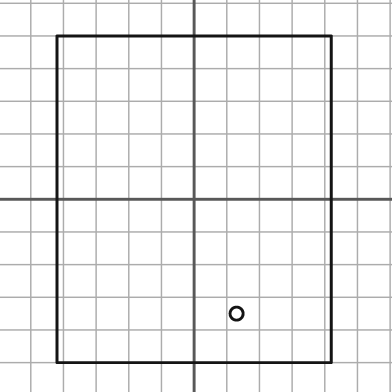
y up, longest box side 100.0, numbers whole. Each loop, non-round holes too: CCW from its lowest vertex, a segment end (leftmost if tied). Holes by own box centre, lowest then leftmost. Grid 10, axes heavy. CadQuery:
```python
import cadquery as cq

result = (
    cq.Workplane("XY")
    .moveTo(-42.0, -50.0)
    .lineTo(42.0, -50.0)
    .lineTo(42.0, 50.0)
    .lineTo(-42.0, 50.0)
    .close()
    .moveTo(13.0, -35.0)
    .circle(2.0)
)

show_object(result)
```